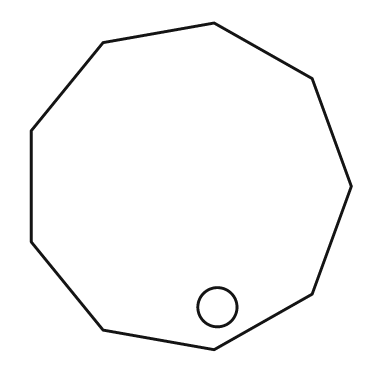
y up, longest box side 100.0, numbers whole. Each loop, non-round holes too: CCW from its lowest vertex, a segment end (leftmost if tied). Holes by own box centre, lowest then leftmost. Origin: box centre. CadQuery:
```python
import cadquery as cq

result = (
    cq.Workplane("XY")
    .moveTo(7.0, -50.0)
    .lineTo(37.0, -33.0)
    .lineTo(49.0, 0.0)
    .lineTo(37.0, 33.0)
    .lineTo(7.0, 50.0)
    .lineTo(-27.0, 44.0)
    .lineTo(-49.0, 17.0)
    .lineTo(-49.0, -17.0)
    .lineTo(-27.0, -44.0)
    .close()
    .moveTo(8.0, -37.0)
    .circle(6.0)
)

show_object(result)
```